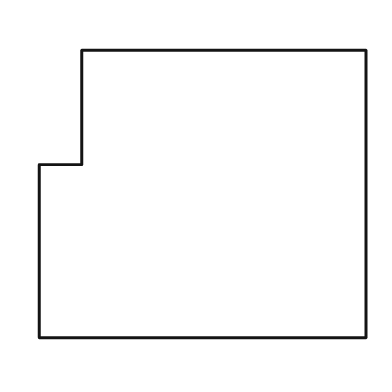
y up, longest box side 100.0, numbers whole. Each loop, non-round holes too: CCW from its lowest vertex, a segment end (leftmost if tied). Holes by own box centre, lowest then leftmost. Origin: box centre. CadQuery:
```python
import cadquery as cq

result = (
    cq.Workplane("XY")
    .moveTo(-50.0, -44.0)
    .lineTo(50.0, -44.0)
    .lineTo(50.0, 44.0)
    .lineTo(-37.0, 44.0)
    .lineTo(-37.0, 9.0)
    .lineTo(-50.0, 9.0)
    .close()
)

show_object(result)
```